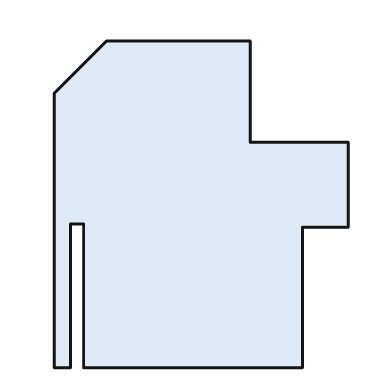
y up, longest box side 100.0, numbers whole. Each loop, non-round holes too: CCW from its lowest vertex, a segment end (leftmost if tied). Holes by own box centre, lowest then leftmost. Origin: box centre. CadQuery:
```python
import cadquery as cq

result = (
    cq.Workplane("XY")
    .moveTo(-45.0, -50.0)
    .lineTo(-40.0, -50.0)
    .lineTo(-40.0, -6.0)
    .lineTo(-36.0, -6.0)
    .lineTo(-36.0, -50.0)
    .lineTo(31.0, -50.0)
    .lineTo(31.0, -7.0)
    .lineTo(45.0, -7.0)
    .lineTo(45.0, 19.0)
    .lineTo(15.0, 19.0)
    .lineTo(15.0, 50.0)
    .lineTo(-29.0, 50.0)
    .lineTo(-45.0, 34.0)
    .close()
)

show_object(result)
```